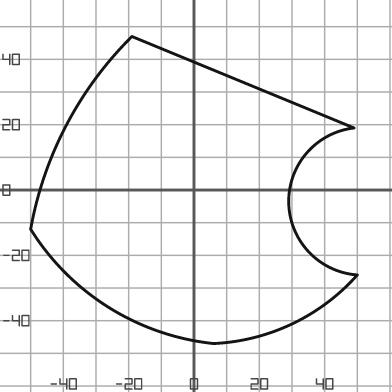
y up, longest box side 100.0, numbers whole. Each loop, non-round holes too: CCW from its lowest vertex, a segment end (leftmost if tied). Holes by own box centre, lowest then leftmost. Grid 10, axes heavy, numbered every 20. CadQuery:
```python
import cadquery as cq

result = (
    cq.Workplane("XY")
    .moveTo(6.0, -47.0)
    .threePointArc((30.0, -41.0), (50.0, -26.0))
    .threePointArc((29.0, -4.0), (49.0, 19.0))
    .lineTo(-19.0, 47.0)
    .threePointArc((-39.0, 20.0), (-50.0, -12.0))
    .threePointArc((-26.0, -36.0), (6.0, -47.0))
    .close()
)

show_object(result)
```